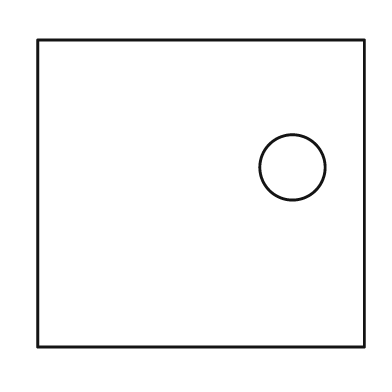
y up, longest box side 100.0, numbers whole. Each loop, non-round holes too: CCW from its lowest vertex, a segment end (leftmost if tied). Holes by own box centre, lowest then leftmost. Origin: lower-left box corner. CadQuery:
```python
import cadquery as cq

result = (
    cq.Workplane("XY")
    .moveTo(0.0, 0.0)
    .lineTo(100.0, 0.0)
    .lineTo(100.0, 94.0)
    .lineTo(0.0, 94.0)
    .close()
    .moveTo(78.0, 55.0)
    .circle(10.0)
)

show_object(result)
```